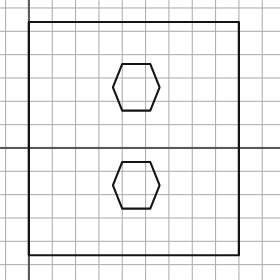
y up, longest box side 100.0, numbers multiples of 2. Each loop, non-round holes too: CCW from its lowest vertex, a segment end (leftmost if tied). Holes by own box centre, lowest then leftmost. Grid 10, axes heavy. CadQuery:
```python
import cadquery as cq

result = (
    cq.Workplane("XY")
    .moveTo(0.0, -46.0)
    .lineTo(90.0, -46.0)
    .lineTo(90.0, 54.0)
    .lineTo(0.0, 54.0)
    .close()
    .moveTo(40.0, -26.0)
    .lineTo(52.0, -26.0)
    .lineTo(56.0, -16.0)
    .lineTo(52.0, -6.0)
    .lineTo(40.0, -6.0)
    .lineTo(36.0, -16.0)
    .close()
    .moveTo(40.0, 16.0)
    .lineTo(52.0, 16.0)
    .lineTo(56.0, 26.0)
    .lineTo(52.0, 36.0)
    .lineTo(40.0, 36.0)
    .lineTo(36.0, 26.0)
    .close()
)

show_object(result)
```